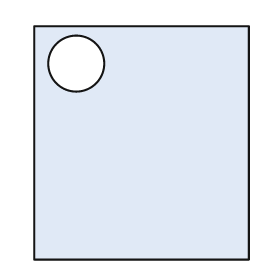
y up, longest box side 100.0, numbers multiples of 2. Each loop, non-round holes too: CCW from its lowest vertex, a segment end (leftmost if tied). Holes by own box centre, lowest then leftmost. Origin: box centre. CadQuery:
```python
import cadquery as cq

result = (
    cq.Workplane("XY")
    .moveTo(-46.0, -50.0)
    .lineTo(46.0, -50.0)
    .lineTo(46.0, 50.0)
    .lineTo(-46.0, 50.0)
    .close()
    .moveTo(-28.0, 34.0)
    .circle(12.0)
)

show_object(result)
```